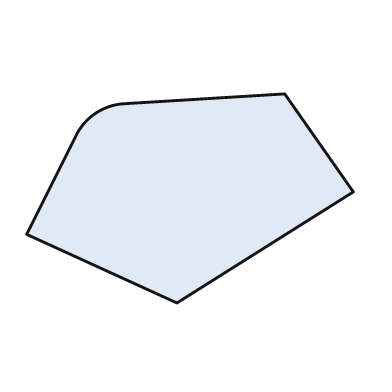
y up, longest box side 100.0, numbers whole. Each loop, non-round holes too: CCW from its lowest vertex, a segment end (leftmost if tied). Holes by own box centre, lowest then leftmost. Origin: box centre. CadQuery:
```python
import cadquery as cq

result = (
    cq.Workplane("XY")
    .moveTo(-4.0, -32.0)
    .lineTo(50.0, 2.0)
    .lineTo(29.0, 32.0)
    .lineTo(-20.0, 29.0)
    .threePointArc((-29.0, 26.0), (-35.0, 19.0))
    .lineTo(-50.0, -11.0)
    .close()
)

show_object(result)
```